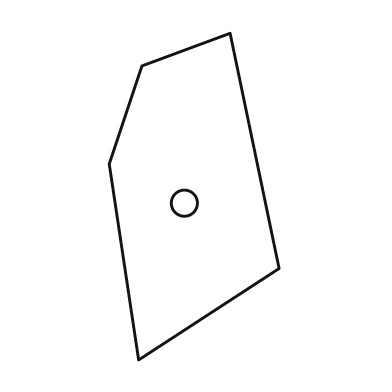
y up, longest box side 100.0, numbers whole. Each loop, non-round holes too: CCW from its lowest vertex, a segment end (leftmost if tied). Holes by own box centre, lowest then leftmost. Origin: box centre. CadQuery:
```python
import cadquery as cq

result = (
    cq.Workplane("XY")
    .moveTo(-17.0, -50.0)
    .lineTo(26.0, -22.0)
    .lineTo(11.0, 50.0)
    .lineTo(-16.0, 40.0)
    .lineTo(-26.0, 10.0)
    .close()
    .moveTo(-3.0, -2.0)
    .circle(4.0)
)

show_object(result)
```